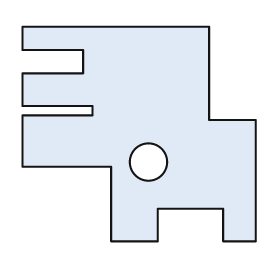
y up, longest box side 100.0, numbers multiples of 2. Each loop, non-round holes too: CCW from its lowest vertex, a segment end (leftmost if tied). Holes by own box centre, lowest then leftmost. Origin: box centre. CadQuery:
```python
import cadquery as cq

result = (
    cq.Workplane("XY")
    .moveTo(-12.0, -46.0)
    .lineTo(8.0, -46.0)
    .lineTo(8.0, -32.0)
    .lineTo(36.0, -32.0)
    .lineTo(36.0, -46.0)
    .lineTo(50.0, -46.0)
    .lineTo(50.0, 6.0)
    .lineTo(30.0, 6.0)
    .lineTo(30.0, 46.0)
    .lineTo(-50.0, 46.0)
    .lineTo(-50.0, 36.0)
    .lineTo(-24.0, 36.0)
    .lineTo(-24.0, 26.0)
    .lineTo(-50.0, 26.0)
    .lineTo(-50.0, 12.0)
    .lineTo(-20.0, 12.0)
    .lineTo(-20.0, 8.0)
    .lineTo(-50.0, 8.0)
    .lineTo(-50.0, -14.0)
    .lineTo(-12.0, -14.0)
    .close()
    .moveTo(4.0, -12.0)
    .circle(8.0)
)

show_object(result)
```